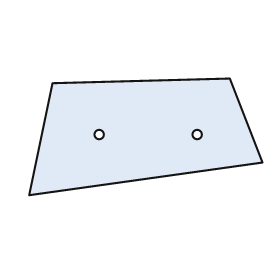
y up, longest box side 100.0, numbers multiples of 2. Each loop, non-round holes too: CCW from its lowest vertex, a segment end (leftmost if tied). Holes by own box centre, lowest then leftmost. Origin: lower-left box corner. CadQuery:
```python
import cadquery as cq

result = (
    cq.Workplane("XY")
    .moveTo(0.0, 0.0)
    .lineTo(100.0, 14.0)
    .lineTo(86.0, 50.0)
    .lineTo(10.0, 48.0)
    .close()
    .moveTo(30.0, 26.0)
    .circle(2.0)
    .moveTo(72.0, 26.0)
    .circle(2.0)
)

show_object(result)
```